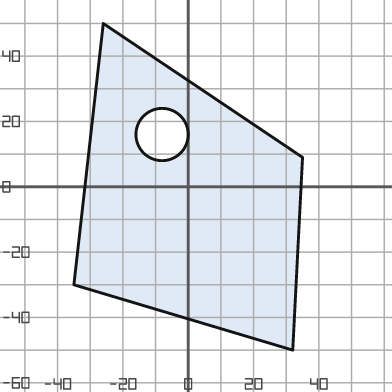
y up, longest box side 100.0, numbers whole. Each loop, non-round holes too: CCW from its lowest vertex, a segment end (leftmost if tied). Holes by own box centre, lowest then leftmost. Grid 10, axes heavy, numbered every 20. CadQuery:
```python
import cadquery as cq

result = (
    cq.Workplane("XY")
    .moveTo(32.0, -50.0)
    .lineTo(35.0, 9.0)
    .lineTo(-26.0, 50.0)
    .lineTo(-35.0, -30.0)
    .close()
    .moveTo(-8.0, 16.0)
    .circle(8.0)
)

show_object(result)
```